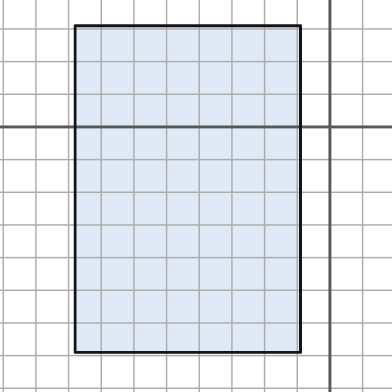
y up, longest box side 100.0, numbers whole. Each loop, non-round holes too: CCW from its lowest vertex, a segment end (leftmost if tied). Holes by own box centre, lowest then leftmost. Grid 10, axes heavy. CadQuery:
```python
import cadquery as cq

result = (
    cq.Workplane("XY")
    .moveTo(-78.0, -69.0)
    .lineTo(-9.0, -69.0)
    .lineTo(-9.0, 31.0)
    .lineTo(-78.0, 31.0)
    .close()
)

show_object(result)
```